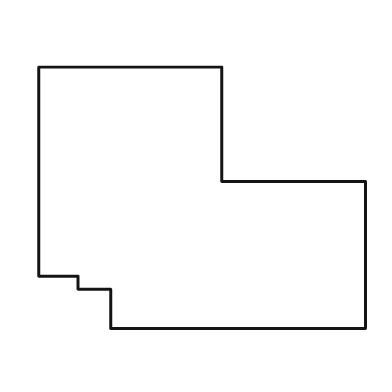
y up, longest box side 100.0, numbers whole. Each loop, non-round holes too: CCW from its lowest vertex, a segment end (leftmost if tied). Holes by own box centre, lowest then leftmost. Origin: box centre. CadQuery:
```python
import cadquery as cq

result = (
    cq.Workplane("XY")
    .moveTo(-28.0, -40.0)
    .lineTo(50.0, -40.0)
    .lineTo(50.0, 5.0)
    .lineTo(6.0, 5.0)
    .lineTo(6.0, 40.0)
    .lineTo(-50.0, 40.0)
    .lineTo(-50.0, -24.0)
    .lineTo(-38.0, -24.0)
    .lineTo(-38.0, -28.0)
    .lineTo(-28.0, -28.0)
    .close()
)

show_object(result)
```